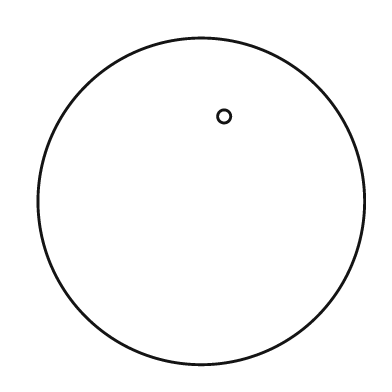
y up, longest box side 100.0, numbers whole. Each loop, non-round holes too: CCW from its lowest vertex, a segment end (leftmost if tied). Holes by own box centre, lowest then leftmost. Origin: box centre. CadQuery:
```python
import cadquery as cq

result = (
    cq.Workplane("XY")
    .moveTo(0.0, 0.0)
    .circle(50.0)
    .moveTo(7.0, 26.0)
    .circle(2.0)
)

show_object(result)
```